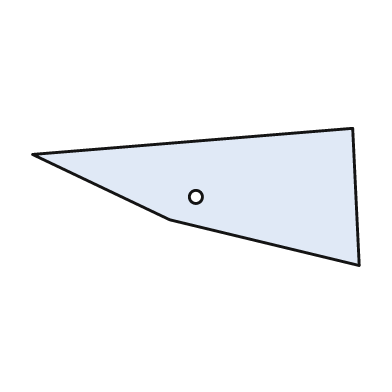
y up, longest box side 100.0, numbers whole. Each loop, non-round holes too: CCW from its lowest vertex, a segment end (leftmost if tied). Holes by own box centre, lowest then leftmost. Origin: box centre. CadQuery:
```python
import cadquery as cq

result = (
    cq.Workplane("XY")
    .moveTo(50.0, -21.0)
    .lineTo(48.0, 21.0)
    .lineTo(-50.0, 13.0)
    .lineTo(-8.0, -7.0)
    .close()
    .moveTo(0.0, 0.0)
    .circle(2.0)
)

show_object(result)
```